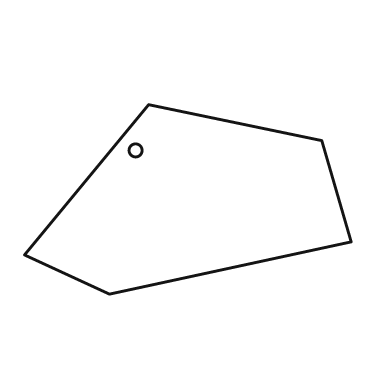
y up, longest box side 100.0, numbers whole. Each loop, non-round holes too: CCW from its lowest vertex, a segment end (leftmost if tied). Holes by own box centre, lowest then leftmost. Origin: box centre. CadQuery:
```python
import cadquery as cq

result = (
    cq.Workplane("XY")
    .moveTo(-24.0, -29.0)
    .lineTo(50.0, -13.0)
    .lineTo(41.0, 18.0)
    .lineTo(-12.0, 29.0)
    .lineTo(-50.0, -17.0)
    .close()
    .moveTo(-16.0, 15.0)
    .circle(2.0)
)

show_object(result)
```